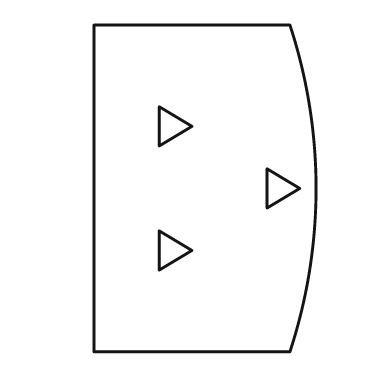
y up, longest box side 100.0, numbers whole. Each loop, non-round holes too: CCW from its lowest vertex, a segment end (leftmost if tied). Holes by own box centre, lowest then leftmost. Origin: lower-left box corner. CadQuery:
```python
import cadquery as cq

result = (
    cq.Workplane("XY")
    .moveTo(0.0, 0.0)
    .lineTo(60.0, 0.0)
    .threePointArc((68.0, 50.0), (60.0, 100.0))
    .lineTo(0.0, 100.0)
    .close()
    .moveTo(20.0, 25.0)
    .lineTo(30.0, 31.0)
    .lineTo(20.0, 37.0)
    .close()
    .moveTo(53.0, 44.0)
    .lineTo(63.0, 50.0)
    .lineTo(53.0, 56.0)
    .close()
    .moveTo(20.0, 63.0)
    .lineTo(30.0, 69.0)
    .lineTo(20.0, 75.0)
    .close()
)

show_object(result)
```